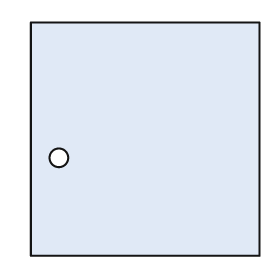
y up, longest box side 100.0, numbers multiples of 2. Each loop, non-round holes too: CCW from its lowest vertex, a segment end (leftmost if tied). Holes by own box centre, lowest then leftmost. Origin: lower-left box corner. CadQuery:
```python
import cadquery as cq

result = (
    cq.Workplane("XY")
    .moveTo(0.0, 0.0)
    .lineTo(98.0, 0.0)
    .lineTo(98.0, 100.0)
    .lineTo(0.0, 100.0)
    .close()
    .moveTo(12.0, 42.0)
    .circle(4.0)
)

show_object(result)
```